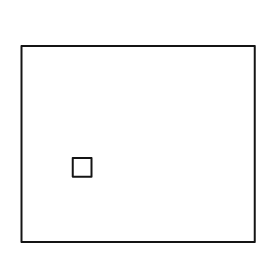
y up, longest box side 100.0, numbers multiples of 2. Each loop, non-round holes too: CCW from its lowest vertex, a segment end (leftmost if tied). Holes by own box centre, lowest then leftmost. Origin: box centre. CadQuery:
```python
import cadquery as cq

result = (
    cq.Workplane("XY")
    .moveTo(-50.0, -42.0)
    .lineTo(50.0, -42.0)
    .lineTo(50.0, 42.0)
    .lineTo(-50.0, 42.0)
    .close()
    .moveTo(-28.0, -14.0)
    .lineTo(-20.0, -14.0)
    .lineTo(-20.0, -6.0)
    .lineTo(-28.0, -6.0)
    .close()
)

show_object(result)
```